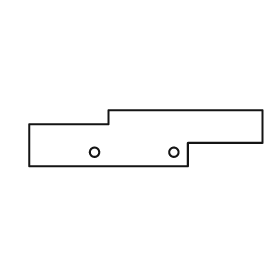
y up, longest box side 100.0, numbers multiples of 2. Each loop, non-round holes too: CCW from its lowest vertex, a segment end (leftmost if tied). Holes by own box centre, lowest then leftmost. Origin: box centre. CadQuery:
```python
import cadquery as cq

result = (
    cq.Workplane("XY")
    .moveTo(-50.0, -12.0)
    .lineTo(18.0, -12.0)
    .lineTo(18.0, -2.0)
    .lineTo(50.0, -2.0)
    .lineTo(50.0, 12.0)
    .lineTo(-16.0, 12.0)
    .lineTo(-16.0, 6.0)
    .lineTo(-50.0, 6.0)
    .close()
    .moveTo(-22.0, -6.0)
    .circle(2.0)
    .moveTo(12.0, -6.0)
    .circle(2.0)
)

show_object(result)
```